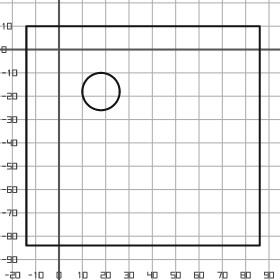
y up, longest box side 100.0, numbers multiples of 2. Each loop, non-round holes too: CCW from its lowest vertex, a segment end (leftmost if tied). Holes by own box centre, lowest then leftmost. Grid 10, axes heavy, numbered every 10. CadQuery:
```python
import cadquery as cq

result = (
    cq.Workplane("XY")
    .moveTo(-14.0, -84.0)
    .lineTo(86.0, -84.0)
    .lineTo(86.0, 10.0)
    .lineTo(-14.0, 10.0)
    .close()
    .moveTo(18.0, -18.0)
    .circle(8.0)
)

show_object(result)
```